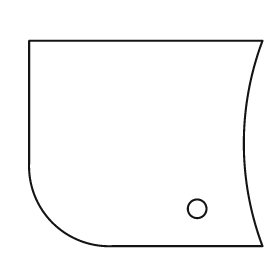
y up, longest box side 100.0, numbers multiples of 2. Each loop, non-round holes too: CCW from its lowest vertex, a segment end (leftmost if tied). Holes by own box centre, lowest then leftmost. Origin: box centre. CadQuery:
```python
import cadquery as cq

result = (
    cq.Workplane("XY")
    .moveTo(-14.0, -44.0)
    .lineTo(50.0, -44.0)
    .threePointArc((42.0, 0.0), (50.0, 44.0))
    .lineTo(-50.0, 44.0)
    .lineTo(-50.0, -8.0)
    .threePointArc((-40.0, -34.0), (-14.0, -44.0))
    .close()
    .moveTo(22.0, -28.0)
    .circle(4.0)
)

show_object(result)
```